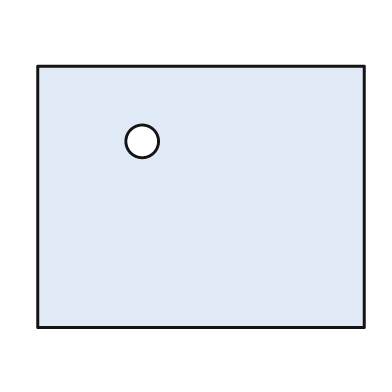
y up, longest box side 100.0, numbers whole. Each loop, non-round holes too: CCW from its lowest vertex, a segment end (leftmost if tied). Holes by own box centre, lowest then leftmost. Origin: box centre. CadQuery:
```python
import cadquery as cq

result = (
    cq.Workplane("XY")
    .moveTo(-50.0, -40.0)
    .lineTo(50.0, -40.0)
    .lineTo(50.0, 40.0)
    .lineTo(-50.0, 40.0)
    .close()
    .moveTo(-18.0, 17.0)
    .circle(5.0)
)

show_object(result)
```